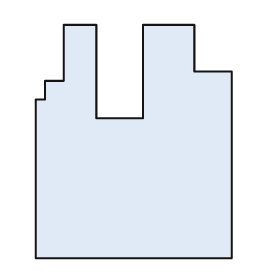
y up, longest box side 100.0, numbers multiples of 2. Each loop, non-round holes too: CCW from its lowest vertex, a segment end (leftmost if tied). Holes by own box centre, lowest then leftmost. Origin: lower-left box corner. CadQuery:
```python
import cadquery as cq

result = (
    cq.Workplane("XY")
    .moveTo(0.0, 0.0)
    .lineTo(84.0, 0.0)
    .lineTo(84.0, 80.0)
    .lineTo(68.0, 80.0)
    .lineTo(68.0, 100.0)
    .lineTo(46.0, 100.0)
    .lineTo(46.0, 60.0)
    .lineTo(26.0, 60.0)
    .lineTo(26.0, 100.0)
    .lineTo(12.0, 100.0)
    .lineTo(12.0, 76.0)
    .lineTo(4.0, 76.0)
    .lineTo(4.0, 68.0)
    .lineTo(0.0, 68.0)
    .close()
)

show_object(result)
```